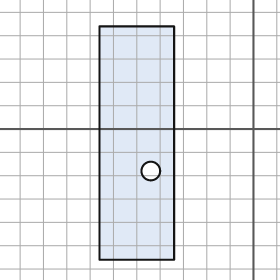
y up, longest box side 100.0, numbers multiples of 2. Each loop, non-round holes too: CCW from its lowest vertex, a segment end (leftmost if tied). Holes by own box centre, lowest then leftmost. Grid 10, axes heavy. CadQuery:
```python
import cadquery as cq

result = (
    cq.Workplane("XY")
    .moveTo(-66.0, -56.0)
    .lineTo(-34.0, -56.0)
    .lineTo(-34.0, 44.0)
    .lineTo(-66.0, 44.0)
    .close()
    .moveTo(-44.0, -18.0)
    .circle(4.0)
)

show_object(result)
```